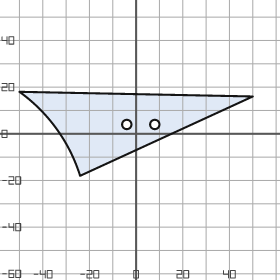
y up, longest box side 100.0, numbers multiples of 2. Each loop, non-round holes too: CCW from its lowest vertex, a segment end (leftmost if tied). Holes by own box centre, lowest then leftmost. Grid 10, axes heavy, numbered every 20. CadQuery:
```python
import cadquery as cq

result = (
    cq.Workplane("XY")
    .moveTo(-24.0, -18.0)
    .lineTo(50.0, 16.0)
    .lineTo(-50.0, 18.0)
    .threePointArc((-34.0, 2.0), (-24.0, -18.0))
    .close()
    .moveTo(-4.0, 4.0)
    .circle(2.0)
    .moveTo(8.0, 4.0)
    .circle(2.0)
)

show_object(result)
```